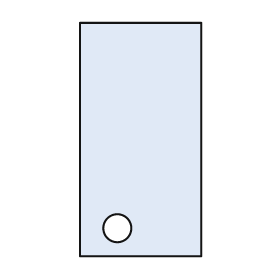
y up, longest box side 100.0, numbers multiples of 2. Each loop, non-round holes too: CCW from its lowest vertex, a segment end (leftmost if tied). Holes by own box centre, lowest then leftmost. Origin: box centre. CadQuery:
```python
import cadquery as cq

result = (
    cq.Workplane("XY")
    .moveTo(-26.0, -50.0)
    .lineTo(26.0, -50.0)
    .lineTo(26.0, 50.0)
    .lineTo(-26.0, 50.0)
    .close()
    .moveTo(-10.0, -38.0)
    .circle(6.0)
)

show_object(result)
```